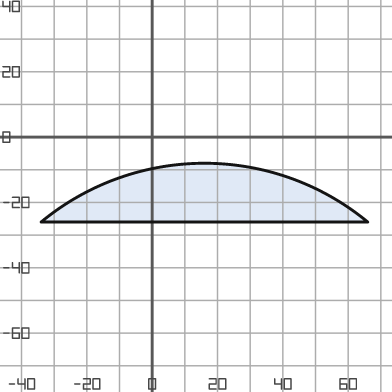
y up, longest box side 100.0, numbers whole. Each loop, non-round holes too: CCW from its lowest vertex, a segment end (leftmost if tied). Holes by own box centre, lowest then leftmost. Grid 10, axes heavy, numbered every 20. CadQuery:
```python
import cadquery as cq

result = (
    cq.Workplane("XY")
    .moveTo(-34.0, -26.0)
    .lineTo(66.0, -26.0)
    .threePointArc((16.0, -8.0), (-34.0, -26.0))
    .close()
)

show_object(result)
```